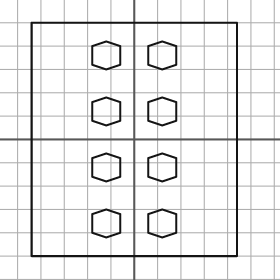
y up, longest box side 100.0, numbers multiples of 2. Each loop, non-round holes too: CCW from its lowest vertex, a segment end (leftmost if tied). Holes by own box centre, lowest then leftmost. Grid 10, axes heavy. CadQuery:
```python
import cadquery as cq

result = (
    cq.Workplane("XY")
    .moveTo(-44.0, -50.0)
    .lineTo(44.0, -50.0)
    .lineTo(44.0, 50.0)
    .lineTo(-44.0, 50.0)
    .close()
    .moveTo(-12.0, -42.0)
    .lineTo(-6.0, -40.0)
    .lineTo(-6.0, -32.0)
    .lineTo(-12.0, -30.0)
    .lineTo(-18.0, -32.0)
    .lineTo(-18.0, -40.0)
    .close()
    .moveTo(12.0, -42.0)
    .lineTo(18.0, -40.0)
    .lineTo(18.0, -32.0)
    .lineTo(12.0, -30.0)
    .lineTo(6.0, -32.0)
    .lineTo(6.0, -40.0)
    .close()
    .moveTo(-12.0, -18.0)
    .lineTo(-6.0, -16.0)
    .lineTo(-6.0, -8.0)
    .lineTo(-12.0, -6.0)
    .lineTo(-18.0, -8.0)
    .lineTo(-18.0, -16.0)
    .close()
    .moveTo(12.0, -18.0)
    .lineTo(18.0, -16.0)
    .lineTo(18.0, -8.0)
    .lineTo(12.0, -6.0)
    .lineTo(6.0, -8.0)
    .lineTo(6.0, -16.0)
    .close()
    .moveTo(-12.0, 6.0)
    .lineTo(-6.0, 8.0)
    .lineTo(-6.0, 16.0)
    .lineTo(-12.0, 18.0)
    .lineTo(-18.0, 16.0)
    .lineTo(-18.0, 8.0)
    .close()
    .moveTo(12.0, 6.0)
    .lineTo(18.0, 8.0)
    .lineTo(18.0, 16.0)
    .lineTo(12.0, 18.0)
    .lineTo(6.0, 16.0)
    .lineTo(6.0, 8.0)
    .close()
    .moveTo(-12.0, 30.0)
    .lineTo(-6.0, 32.0)
    .lineTo(-6.0, 40.0)
    .lineTo(-12.0, 42.0)
    .lineTo(-18.0, 40.0)
    .lineTo(-18.0, 32.0)
    .close()
    .moveTo(12.0, 30.0)
    .lineTo(18.0, 32.0)
    .lineTo(18.0, 40.0)
    .lineTo(12.0, 42.0)
    .lineTo(6.0, 40.0)
    .lineTo(6.0, 32.0)
    .close()
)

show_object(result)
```